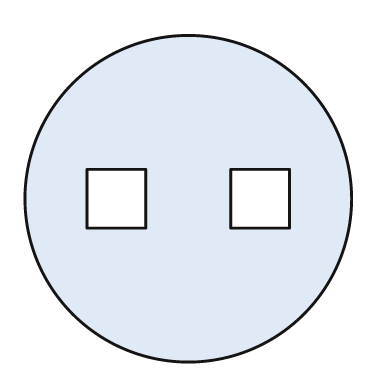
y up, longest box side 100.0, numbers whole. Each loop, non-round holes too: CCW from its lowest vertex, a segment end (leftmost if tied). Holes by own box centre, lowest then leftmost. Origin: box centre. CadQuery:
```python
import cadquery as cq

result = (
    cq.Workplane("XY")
    .moveTo(0.0, 0.0)
    .circle(50.0)
    .moveTo(-31.0, -9.0)
    .lineTo(-13.0, -9.0)
    .lineTo(-13.0, 9.0)
    .lineTo(-31.0, 9.0)
    .close()
    .moveTo(13.0, -9.0)
    .lineTo(31.0, -9.0)
    .lineTo(31.0, 9.0)
    .lineTo(13.0, 9.0)
    .close()
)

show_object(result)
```